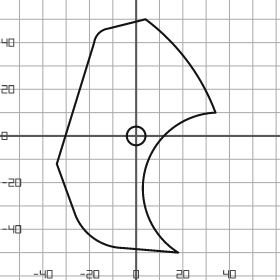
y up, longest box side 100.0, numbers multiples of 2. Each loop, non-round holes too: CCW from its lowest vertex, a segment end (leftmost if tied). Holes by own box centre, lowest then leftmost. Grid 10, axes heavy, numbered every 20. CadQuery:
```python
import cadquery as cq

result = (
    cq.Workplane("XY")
    .moveTo(18.0, -50.0)
    .threePointArc((4.0, -14.0), (34.0, 10.0))
    .threePointArc((22.0, 32.0), (4.0, 50.0))
    .lineTo(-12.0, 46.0)
    .threePointArc((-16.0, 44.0), (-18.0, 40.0))
    .lineTo(-34.0, -12.0)
    .lineTo(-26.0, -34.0)
    .threePointArc((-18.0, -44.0), (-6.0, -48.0))
    .close()
    .moveTo(0.0, 0.0)
    .circle(4.0)
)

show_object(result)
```